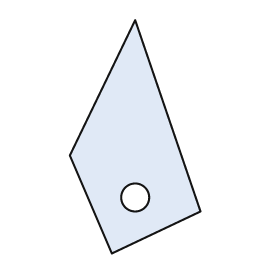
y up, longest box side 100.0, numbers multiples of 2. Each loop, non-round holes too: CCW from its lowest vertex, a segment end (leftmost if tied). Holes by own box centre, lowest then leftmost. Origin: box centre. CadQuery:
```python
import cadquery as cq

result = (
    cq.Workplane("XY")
    .moveTo(-10.0, -50.0)
    .lineTo(28.0, -32.0)
    .lineTo(0.0, 50.0)
    .lineTo(-28.0, -8.0)
    .close()
    .moveTo(0.0, -26.0)
    .circle(6.0)
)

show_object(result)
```